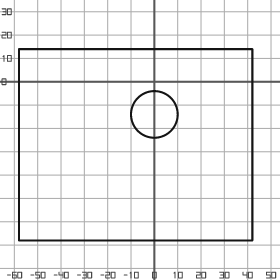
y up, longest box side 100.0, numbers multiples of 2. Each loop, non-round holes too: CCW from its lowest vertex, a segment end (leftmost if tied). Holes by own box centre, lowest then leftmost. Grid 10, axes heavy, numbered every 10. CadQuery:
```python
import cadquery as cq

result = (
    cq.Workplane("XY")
    .moveTo(-58.0, -68.0)
    .lineTo(42.0, -68.0)
    .lineTo(42.0, 14.0)
    .lineTo(-58.0, 14.0)
    .close()
    .moveTo(0.0, -14.0)
    .circle(10.0)
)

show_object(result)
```